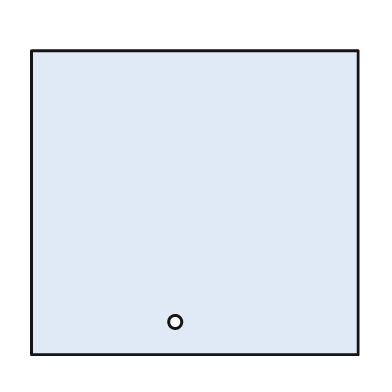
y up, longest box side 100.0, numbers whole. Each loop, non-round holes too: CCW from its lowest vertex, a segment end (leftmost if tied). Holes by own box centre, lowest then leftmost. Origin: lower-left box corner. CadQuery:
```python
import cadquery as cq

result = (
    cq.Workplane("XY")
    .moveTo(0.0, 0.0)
    .lineTo(100.0, 0.0)
    .lineTo(100.0, 93.0)
    .lineTo(0.0, 93.0)
    .close()
    .moveTo(44.0, 10.0)
    .circle(2.0)
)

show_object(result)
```